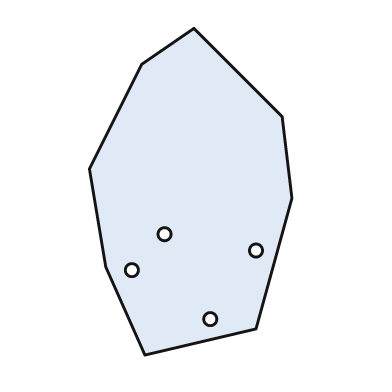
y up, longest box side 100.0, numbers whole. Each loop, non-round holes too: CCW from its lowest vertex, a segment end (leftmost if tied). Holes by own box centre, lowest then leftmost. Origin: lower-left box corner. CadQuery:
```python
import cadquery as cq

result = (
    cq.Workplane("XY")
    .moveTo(17.0, 0.0)
    .lineTo(51.0, 8.0)
    .lineTo(62.0, 48.0)
    .lineTo(59.0, 73.0)
    .lineTo(32.0, 100.0)
    .lineTo(16.0, 89.0)
    .lineTo(0.0, 57.0)
    .lineTo(5.0, 27.0)
    .close()
    .moveTo(37.0, 11.0)
    .circle(2.0)
    .moveTo(13.0, 26.0)
    .circle(2.0)
    .moveTo(51.0, 32.0)
    .circle(2.0)
    .moveTo(23.0, 37.0)
    .circle(2.0)
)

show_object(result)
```